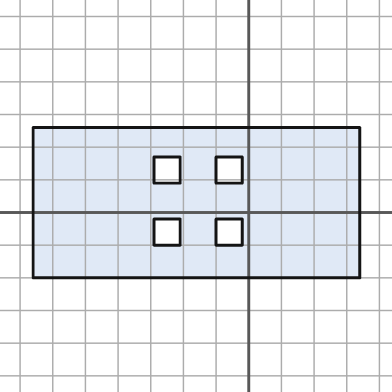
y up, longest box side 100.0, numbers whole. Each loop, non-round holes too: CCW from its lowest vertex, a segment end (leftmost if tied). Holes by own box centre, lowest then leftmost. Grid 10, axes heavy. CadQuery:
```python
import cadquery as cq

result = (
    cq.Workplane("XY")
    .moveTo(-66.0, -20.0)
    .lineTo(34.0, -20.0)
    .lineTo(34.0, 26.0)
    .lineTo(-66.0, 26.0)
    .close()
    .moveTo(-29.0, -10.0)
    .lineTo(-21.0, -10.0)
    .lineTo(-21.0, -2.0)
    .lineTo(-29.0, -2.0)
    .close()
    .moveTo(-10.0, -10.0)
    .lineTo(-2.0, -10.0)
    .lineTo(-2.0, -2.0)
    .lineTo(-10.0, -2.0)
    .close()
    .moveTo(-29.0, 9.0)
    .lineTo(-21.0, 9.0)
    .lineTo(-21.0, 17.0)
    .lineTo(-29.0, 17.0)
    .close()
    .moveTo(-10.0, 9.0)
    .lineTo(-2.0, 9.0)
    .lineTo(-2.0, 17.0)
    .lineTo(-10.0, 17.0)
    .close()
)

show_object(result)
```